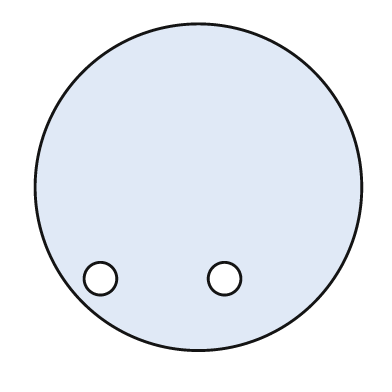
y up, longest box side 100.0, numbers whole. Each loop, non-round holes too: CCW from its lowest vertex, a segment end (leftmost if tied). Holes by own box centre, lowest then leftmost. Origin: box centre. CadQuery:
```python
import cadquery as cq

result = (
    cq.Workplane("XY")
    .moveTo(0.0, 0.0)
    .circle(50.0)
    .moveTo(-30.0, -28.0)
    .circle(5.0)
    .moveTo(8.0, -28.0)
    .circle(5.0)
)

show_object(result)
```